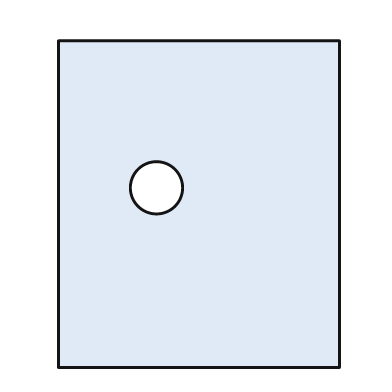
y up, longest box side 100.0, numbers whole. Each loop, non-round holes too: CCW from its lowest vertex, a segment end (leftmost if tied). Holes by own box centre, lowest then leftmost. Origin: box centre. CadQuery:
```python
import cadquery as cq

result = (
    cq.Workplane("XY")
    .moveTo(-43.0, -50.0)
    .lineTo(43.0, -50.0)
    .lineTo(43.0, 50.0)
    .lineTo(-43.0, 50.0)
    .close()
    .moveTo(-13.0, 5.0)
    .circle(8.0)
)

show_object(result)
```